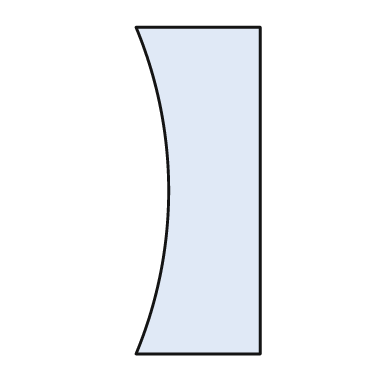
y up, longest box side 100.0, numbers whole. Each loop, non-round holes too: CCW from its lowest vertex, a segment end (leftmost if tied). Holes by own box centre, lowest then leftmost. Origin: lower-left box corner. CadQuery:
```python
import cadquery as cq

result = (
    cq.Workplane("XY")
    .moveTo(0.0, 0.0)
    .lineTo(38.0, 0.0)
    .lineTo(38.0, 100.0)
    .lineTo(0.0, 100.0)
    .threePointArc((10.0, 50.0), (0.0, 0.0))
    .close()
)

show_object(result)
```